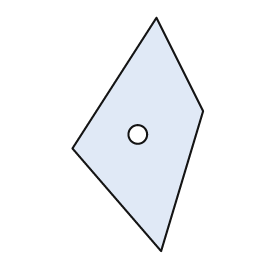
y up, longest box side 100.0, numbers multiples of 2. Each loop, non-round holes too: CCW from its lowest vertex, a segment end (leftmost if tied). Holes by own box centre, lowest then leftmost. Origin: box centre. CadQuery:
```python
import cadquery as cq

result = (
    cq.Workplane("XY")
    .moveTo(10.0, -50.0)
    .lineTo(28.0, 10.0)
    .lineTo(8.0, 50.0)
    .lineTo(-28.0, -6.0)
    .close()
    .moveTo(0.0, 0.0)
    .circle(4.0)
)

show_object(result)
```